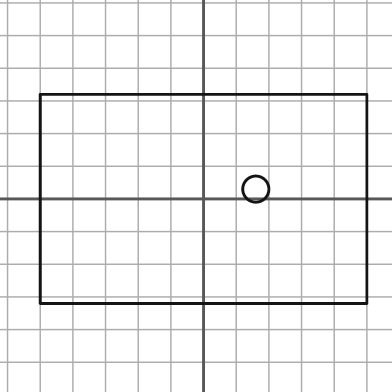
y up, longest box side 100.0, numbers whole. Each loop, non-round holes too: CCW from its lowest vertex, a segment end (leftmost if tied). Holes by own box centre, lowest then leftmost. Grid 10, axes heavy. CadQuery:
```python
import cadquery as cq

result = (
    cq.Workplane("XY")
    .moveTo(-50.0, -32.0)
    .lineTo(50.0, -32.0)
    .lineTo(50.0, 32.0)
    .lineTo(-50.0, 32.0)
    .close()
    .moveTo(16.0, 3.0)
    .circle(4.0)
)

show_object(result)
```